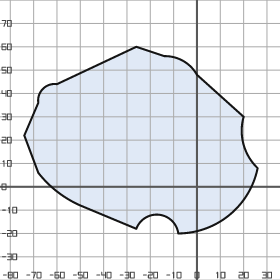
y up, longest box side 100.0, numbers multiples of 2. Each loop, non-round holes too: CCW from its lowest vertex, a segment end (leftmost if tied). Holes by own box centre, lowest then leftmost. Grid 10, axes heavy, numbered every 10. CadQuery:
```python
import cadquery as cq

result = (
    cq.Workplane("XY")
    .moveTo(-8.0, -20.0)
    .threePointArc((14.0, -12.0), (26.0, 8.0))
    .threePointArc((20.0, 18.0), (20.0, 30.0))
    .lineTo(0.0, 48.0)
    .threePointArc((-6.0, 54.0), (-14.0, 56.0))
    .lineTo(-26.0, 60.0)
    .lineTo(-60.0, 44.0)
    .threePointArc((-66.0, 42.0), (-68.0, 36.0))
    .lineTo(-74.0, 22.0)
    .lineTo(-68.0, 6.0)
    .threePointArc((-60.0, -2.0), (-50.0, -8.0))
    .lineTo(-26.0, -18.0)
    .threePointArc((-16.0, -12.0), (-8.0, -20.0))
    .close()
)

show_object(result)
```